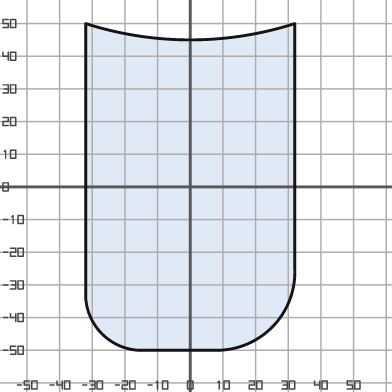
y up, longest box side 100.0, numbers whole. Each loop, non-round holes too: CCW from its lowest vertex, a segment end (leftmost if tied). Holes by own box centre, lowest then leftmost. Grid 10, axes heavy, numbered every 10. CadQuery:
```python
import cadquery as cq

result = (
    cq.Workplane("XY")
    .moveTo(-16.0, -50.0)
    .lineTo(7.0, -50.0)
    .threePointArc((25.0, -43.0), (32.0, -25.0))
    .lineTo(32.0, 50.0)
    .threePointArc((0.0, 45.0), (-32.0, 50.0))
    .lineTo(-32.0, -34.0)
    .threePointArc((-27.0, -45.0), (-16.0, -50.0))
    .close()
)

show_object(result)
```